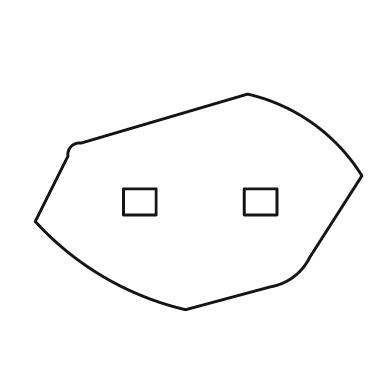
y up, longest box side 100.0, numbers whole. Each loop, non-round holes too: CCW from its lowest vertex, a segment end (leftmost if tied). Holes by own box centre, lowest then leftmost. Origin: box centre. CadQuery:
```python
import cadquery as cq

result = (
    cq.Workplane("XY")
    .moveTo(-4.0, -33.0)
    .lineTo(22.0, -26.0)
    .threePointArc((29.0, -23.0), (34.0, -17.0))
    .lineTo(50.0, 8.0)
    .threePointArc((35.0, 24.0), (15.0, 33.0))
    .lineTo(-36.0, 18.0)
    .threePointArc((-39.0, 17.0), (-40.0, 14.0))
    .lineTo(-50.0, -6.0)
    .threePointArc((-29.0, -23.0), (-4.0, -33.0))
    .close()
    .moveTo(-23.0, -4.0)
    .lineTo(-13.0, -4.0)
    .lineTo(-13.0, 4.0)
    .lineTo(-23.0, 4.0)
    .close()
    .moveTo(14.0, -4.0)
    .lineTo(24.0, -4.0)
    .lineTo(24.0, 4.0)
    .lineTo(14.0, 4.0)
    .close()
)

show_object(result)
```